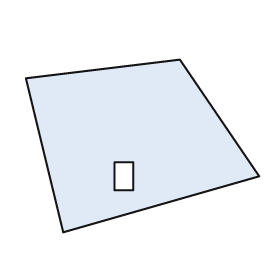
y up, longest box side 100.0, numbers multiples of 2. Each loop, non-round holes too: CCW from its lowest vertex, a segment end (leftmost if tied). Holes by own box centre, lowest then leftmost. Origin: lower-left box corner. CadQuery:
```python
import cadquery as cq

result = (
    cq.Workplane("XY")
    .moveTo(16.0, 0.0)
    .lineTo(100.0, 24.0)
    .lineTo(66.0, 74.0)
    .lineTo(0.0, 66.0)
    .close()
    .moveTo(38.0, 18.0)
    .lineTo(46.0, 18.0)
    .lineTo(46.0, 30.0)
    .lineTo(38.0, 30.0)
    .close()
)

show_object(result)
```